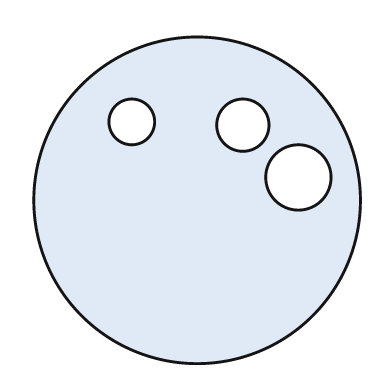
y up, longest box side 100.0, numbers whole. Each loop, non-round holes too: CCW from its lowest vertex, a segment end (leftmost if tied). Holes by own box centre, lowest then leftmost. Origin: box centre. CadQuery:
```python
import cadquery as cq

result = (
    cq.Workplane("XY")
    .moveTo(0.0, 0.0)
    .circle(50.0)
    .moveTo(31.0, 7.0)
    .circle(10.0)
    .moveTo(14.0, 23.0)
    .circle(8.0)
    .moveTo(-20.0, 24.0)
    .circle(7.0)
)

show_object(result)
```